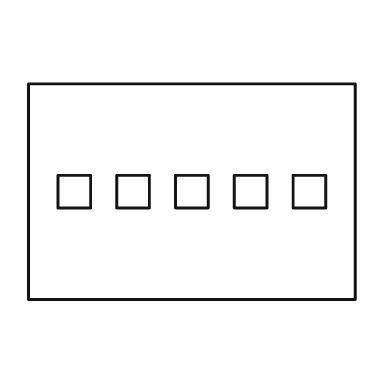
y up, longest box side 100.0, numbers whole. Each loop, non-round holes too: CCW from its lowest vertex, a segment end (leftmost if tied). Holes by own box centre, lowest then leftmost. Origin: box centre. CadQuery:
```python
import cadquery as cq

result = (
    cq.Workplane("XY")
    .moveTo(-50.0, -33.0)
    .lineTo(50.0, -33.0)
    .lineTo(50.0, 33.0)
    .lineTo(-50.0, 33.0)
    .close()
    .moveTo(-41.0, -5.0)
    .lineTo(-31.0, -5.0)
    .lineTo(-31.0, 5.0)
    .lineTo(-41.0, 5.0)
    .close()
    .moveTo(-23.0, -5.0)
    .lineTo(-13.0, -5.0)
    .lineTo(-13.0, 5.0)
    .lineTo(-23.0, 5.0)
    .close()
    .moveTo(-5.0, -5.0)
    .lineTo(5.0, -5.0)
    .lineTo(5.0, 5.0)
    .lineTo(-5.0, 5.0)
    .close()
    .moveTo(13.0, -5.0)
    .lineTo(23.0, -5.0)
    .lineTo(23.0, 5.0)
    .lineTo(13.0, 5.0)
    .close()
    .moveTo(31.0, -5.0)
    .lineTo(41.0, -5.0)
    .lineTo(41.0, 5.0)
    .lineTo(31.0, 5.0)
    .close()
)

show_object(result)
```